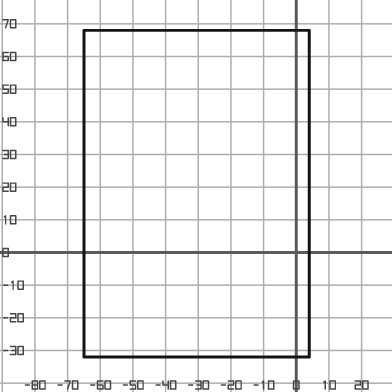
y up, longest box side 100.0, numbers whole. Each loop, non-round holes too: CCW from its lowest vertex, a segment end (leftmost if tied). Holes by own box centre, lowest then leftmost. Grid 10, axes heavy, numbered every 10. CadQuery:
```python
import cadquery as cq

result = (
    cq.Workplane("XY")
    .moveTo(-65.0, -32.0)
    .lineTo(4.0, -32.0)
    .lineTo(4.0, 68.0)
    .lineTo(-65.0, 68.0)
    .close()
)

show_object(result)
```